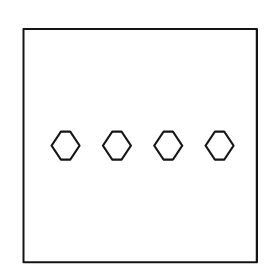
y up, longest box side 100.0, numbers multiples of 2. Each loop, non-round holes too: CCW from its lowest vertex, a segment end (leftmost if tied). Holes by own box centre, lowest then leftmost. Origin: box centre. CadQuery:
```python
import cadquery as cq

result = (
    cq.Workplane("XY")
    .moveTo(-50.0, -50.0)
    .lineTo(50.0, -50.0)
    .lineTo(50.0, 50.0)
    .lineTo(-50.0, 50.0)
    .close()
    .moveTo(-34.0, -6.0)
    .lineTo(-30.0, -6.0)
    .lineTo(-26.0, 0.0)
    .lineTo(-30.0, 6.0)
    .lineTo(-34.0, 6.0)
    .lineTo(-38.0, 0.0)
    .close()
    .moveTo(-12.0, -6.0)
    .lineTo(-8.0, -6.0)
    .lineTo(-4.0, 0.0)
    .lineTo(-8.0, 6.0)
    .lineTo(-12.0, 6.0)
    .lineTo(-16.0, 0.0)
    .close()
    .moveTo(10.0, -6.0)
    .lineTo(14.0, -6.0)
    .lineTo(18.0, 0.0)
    .lineTo(14.0, 6.0)
    .lineTo(10.0, 6.0)
    .lineTo(6.0, 0.0)
    .close()
    .moveTo(32.0, -6.0)
    .lineTo(36.0, -6.0)
    .lineTo(40.0, 0.0)
    .lineTo(36.0, 6.0)
    .lineTo(32.0, 6.0)
    .lineTo(28.0, 0.0)
    .close()
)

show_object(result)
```